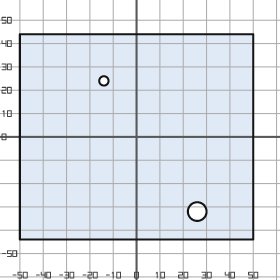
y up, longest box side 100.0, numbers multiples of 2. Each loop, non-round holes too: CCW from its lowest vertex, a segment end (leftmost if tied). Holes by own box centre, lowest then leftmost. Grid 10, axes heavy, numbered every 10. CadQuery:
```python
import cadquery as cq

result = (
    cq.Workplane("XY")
    .moveTo(-50.0, -44.0)
    .lineTo(50.0, -44.0)
    .lineTo(50.0, 44.0)
    .lineTo(-50.0, 44.0)
    .close()
    .moveTo(26.0, -32.0)
    .circle(4.0)
    .moveTo(-14.0, 24.0)
    .circle(2.0)
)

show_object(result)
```